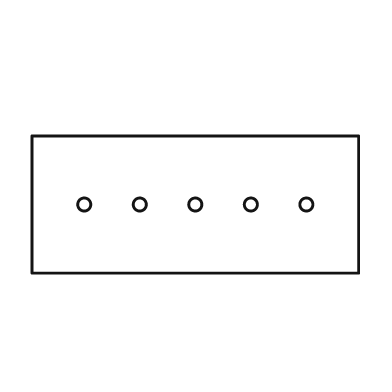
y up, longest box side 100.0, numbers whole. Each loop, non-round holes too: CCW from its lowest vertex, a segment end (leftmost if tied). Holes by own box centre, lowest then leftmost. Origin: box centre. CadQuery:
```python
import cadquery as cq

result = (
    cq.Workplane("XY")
    .moveTo(-50.0, -21.0)
    .lineTo(50.0, -21.0)
    .lineTo(50.0, 21.0)
    .lineTo(-50.0, 21.0)
    .close()
    .moveTo(-34.0, 0.0)
    .circle(2.0)
    .moveTo(-17.0, 0.0)
    .circle(2.0)
    .moveTo(0.0, 0.0)
    .circle(2.0)
    .moveTo(17.0, 0.0)
    .circle(2.0)
    .moveTo(34.0, 0.0)
    .circle(2.0)
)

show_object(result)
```